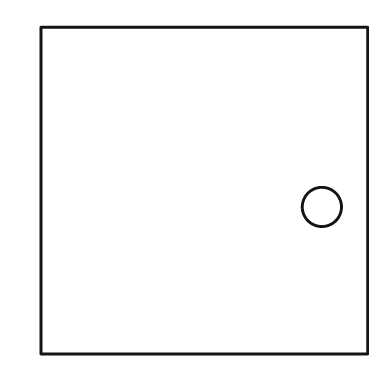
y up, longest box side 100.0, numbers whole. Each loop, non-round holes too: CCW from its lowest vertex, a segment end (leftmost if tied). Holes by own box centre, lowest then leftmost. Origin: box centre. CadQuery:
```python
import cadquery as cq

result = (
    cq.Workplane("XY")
    .moveTo(-50.0, -50.0)
    .lineTo(50.0, -50.0)
    .lineTo(50.0, 50.0)
    .lineTo(-50.0, 50.0)
    .close()
    .moveTo(36.0, -5.0)
    .circle(6.0)
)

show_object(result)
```